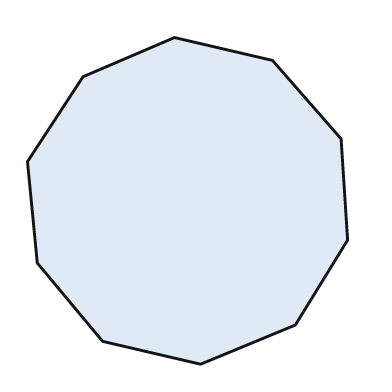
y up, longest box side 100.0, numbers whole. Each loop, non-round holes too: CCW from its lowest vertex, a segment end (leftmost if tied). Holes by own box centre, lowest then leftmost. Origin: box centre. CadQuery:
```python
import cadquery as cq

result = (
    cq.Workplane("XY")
    .moveTo(4.0, -50.0)
    .lineTo(33.0, -38.0)
    .lineTo(49.0, -12.0)
    .lineTo(47.0, 19.0)
    .lineTo(26.0, 43.0)
    .lineTo(-4.0, 50.0)
    .lineTo(-32.0, 38.0)
    .lineTo(-49.0, 12.0)
    .lineTo(-46.0, -19.0)
    .lineTo(-26.0, -43.0)
    .close()
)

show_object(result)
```